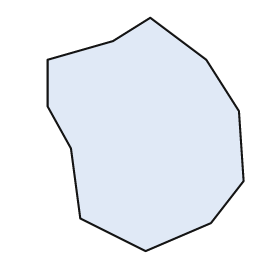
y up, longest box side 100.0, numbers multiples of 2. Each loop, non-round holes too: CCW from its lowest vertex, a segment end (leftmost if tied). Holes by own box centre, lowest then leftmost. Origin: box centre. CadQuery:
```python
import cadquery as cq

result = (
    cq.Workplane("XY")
    .moveTo(0.0, -50.0)
    .lineTo(28.0, -38.0)
    .lineTo(42.0, -20.0)
    .lineTo(40.0, 10.0)
    .lineTo(26.0, 32.0)
    .lineTo(2.0, 50.0)
    .lineTo(-14.0, 40.0)
    .lineTo(-42.0, 32.0)
    .lineTo(-42.0, 12.0)
    .lineTo(-32.0, -6.0)
    .lineTo(-28.0, -36.0)
    .close()
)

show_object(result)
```